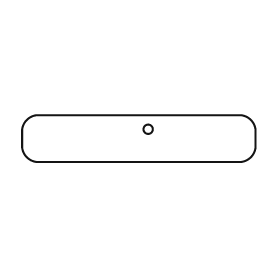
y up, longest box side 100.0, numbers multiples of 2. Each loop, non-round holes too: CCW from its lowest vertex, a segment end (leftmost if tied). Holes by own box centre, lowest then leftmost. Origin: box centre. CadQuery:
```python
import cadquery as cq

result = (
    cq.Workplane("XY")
    .moveTo(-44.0, -10.0)
    .lineTo(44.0, -10.0)
    .threePointArc((48.0, -8.0), (50.0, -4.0))
    .lineTo(50.0, 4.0)
    .threePointArc((48.0, 8.0), (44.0, 10.0))
    .lineTo(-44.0, 10.0)
    .threePointArc((-48.0, 8.0), (-50.0, 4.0))
    .lineTo(-50.0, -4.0)
    .threePointArc((-48.0, -8.0), (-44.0, -10.0))
    .close()
    .moveTo(4.0, 4.0)
    .circle(2.0)
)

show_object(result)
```